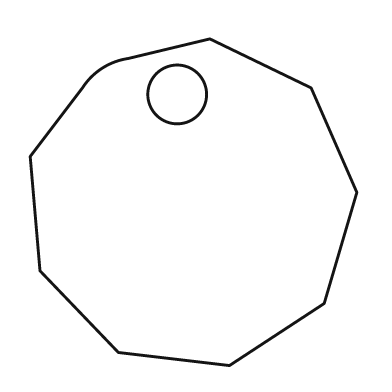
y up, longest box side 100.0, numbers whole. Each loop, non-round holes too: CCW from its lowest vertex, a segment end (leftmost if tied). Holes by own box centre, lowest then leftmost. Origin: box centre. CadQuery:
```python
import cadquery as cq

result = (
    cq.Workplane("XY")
    .moveTo(11.0, -50.0)
    .lineTo(40.0, -31.0)
    .lineTo(50.0, 3.0)
    .lineTo(36.0, 35.0)
    .lineTo(5.0, 50.0)
    .lineTo(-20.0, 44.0)
    .threePointArc((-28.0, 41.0), (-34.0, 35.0))
    .lineTo(-50.0, 14.0)
    .lineTo(-47.0, -21.0)
    .lineTo(-23.0, -46.0)
    .close()
    .moveTo(-5.0, 33.0)
    .circle(9.0)
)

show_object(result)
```